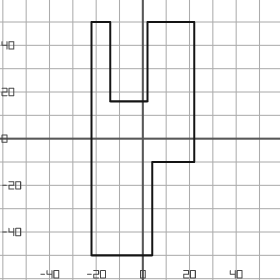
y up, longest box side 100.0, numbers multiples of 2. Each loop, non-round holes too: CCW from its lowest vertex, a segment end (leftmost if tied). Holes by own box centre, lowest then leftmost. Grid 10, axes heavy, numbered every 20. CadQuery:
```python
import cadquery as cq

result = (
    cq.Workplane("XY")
    .moveTo(-22.0, -50.0)
    .lineTo(4.0, -50.0)
    .lineTo(4.0, -10.0)
    .lineTo(22.0, -10.0)
    .lineTo(22.0, 50.0)
    .lineTo(2.0, 50.0)
    .lineTo(2.0, 16.0)
    .lineTo(-14.0, 16.0)
    .lineTo(-14.0, 50.0)
    .lineTo(-22.0, 50.0)
    .close()
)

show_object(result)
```